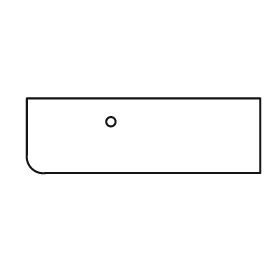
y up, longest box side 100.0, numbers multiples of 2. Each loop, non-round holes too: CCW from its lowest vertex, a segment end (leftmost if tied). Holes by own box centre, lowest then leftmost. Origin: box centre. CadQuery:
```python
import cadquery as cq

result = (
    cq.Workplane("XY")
    .moveTo(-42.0, -16.0)
    .lineTo(50.0, -16.0)
    .lineTo(50.0, 16.0)
    .lineTo(-50.0, 16.0)
    .lineTo(-50.0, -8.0)
    .threePointArc((-48.0, -14.0), (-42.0, -16.0))
    .close()
    .moveTo(-14.0, 6.0)
    .circle(2.0)
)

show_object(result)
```